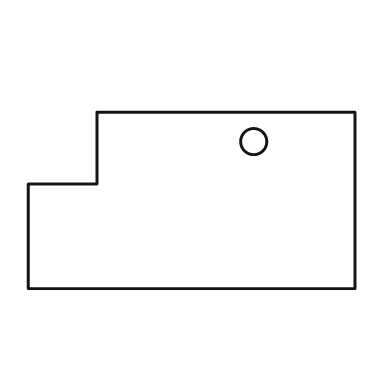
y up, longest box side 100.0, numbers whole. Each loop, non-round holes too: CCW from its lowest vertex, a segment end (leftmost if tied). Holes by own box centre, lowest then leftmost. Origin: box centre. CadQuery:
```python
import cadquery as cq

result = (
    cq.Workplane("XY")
    .moveTo(-50.0, -27.0)
    .lineTo(50.0, -27.0)
    .lineTo(50.0, 27.0)
    .lineTo(-29.0, 27.0)
    .lineTo(-29.0, 5.0)
    .lineTo(-50.0, 5.0)
    .close()
    .moveTo(19.0, 18.0)
    .circle(4.0)
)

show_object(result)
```